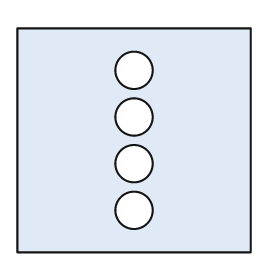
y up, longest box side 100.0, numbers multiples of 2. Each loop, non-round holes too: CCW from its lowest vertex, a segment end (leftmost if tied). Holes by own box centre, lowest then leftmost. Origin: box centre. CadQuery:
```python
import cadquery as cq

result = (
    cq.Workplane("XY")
    .moveTo(-50.0, -48.0)
    .lineTo(50.0, -48.0)
    .lineTo(50.0, 48.0)
    .lineTo(-50.0, 48.0)
    .close()
    .moveTo(0.0, -30.0)
    .circle(8.0)
    .moveTo(0.0, -10.0)
    .circle(8.0)
    .moveTo(0.0, 10.0)
    .circle(8.0)
    .moveTo(0.0, 30.0)
    .circle(8.0)
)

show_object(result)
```